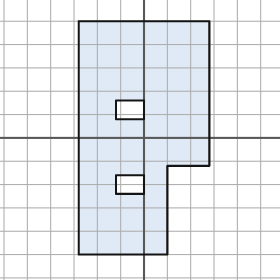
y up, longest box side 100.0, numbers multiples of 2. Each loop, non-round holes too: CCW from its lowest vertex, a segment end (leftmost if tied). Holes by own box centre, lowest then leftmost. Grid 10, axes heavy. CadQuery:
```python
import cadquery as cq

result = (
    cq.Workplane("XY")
    .moveTo(-28.0, -50.0)
    .lineTo(10.0, -50.0)
    .lineTo(10.0, -12.0)
    .lineTo(28.0, -12.0)
    .lineTo(28.0, 50.0)
    .lineTo(-28.0, 50.0)
    .close()
    .moveTo(-12.0, -24.0)
    .lineTo(0.0, -24.0)
    .lineTo(0.0, -16.0)
    .lineTo(-12.0, -16.0)
    .close()
    .moveTo(-12.0, 8.0)
    .lineTo(0.0, 8.0)
    .lineTo(0.0, 16.0)
    .lineTo(-12.0, 16.0)
    .close()
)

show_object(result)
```